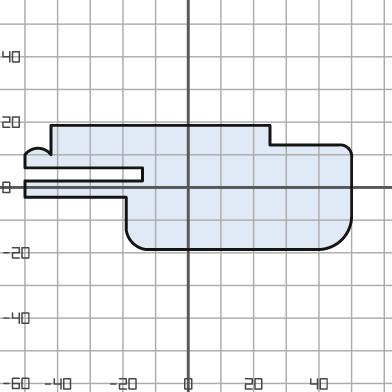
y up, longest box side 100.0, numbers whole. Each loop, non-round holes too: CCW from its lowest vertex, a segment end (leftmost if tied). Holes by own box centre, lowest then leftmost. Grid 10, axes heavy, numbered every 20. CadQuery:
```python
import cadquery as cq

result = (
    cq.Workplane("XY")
    .moveTo(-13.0, -19.0)
    .lineTo(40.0, -19.0)
    .threePointArc((47.0, -16.0), (50.0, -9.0))
    .lineTo(50.0, 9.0)
    .threePointArc((49.0, 12.0), (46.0, 13.0))
    .lineTo(25.0, 13.0)
    .lineTo(25.0, 19.0)
    .lineTo(-42.0, 19.0)
    .lineTo(-42.0, 10.0)
    .threePointArc((-46.0, 12.0), (-50.0, 10.0))
    .lineTo(-50.0, 6.0)
    .lineTo(-14.0, 6.0)
    .lineTo(-14.0, 2.0)
    .lineTo(-50.0, 2.0)
    .lineTo(-50.0, -3.0)
    .lineTo(-19.0, -3.0)
    .lineTo(-19.0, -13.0)
    .threePointArc((-17.0, -17.0), (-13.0, -19.0))
    .close()
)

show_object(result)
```